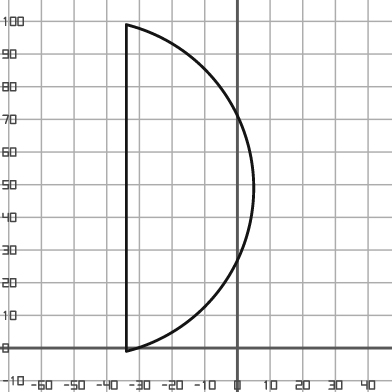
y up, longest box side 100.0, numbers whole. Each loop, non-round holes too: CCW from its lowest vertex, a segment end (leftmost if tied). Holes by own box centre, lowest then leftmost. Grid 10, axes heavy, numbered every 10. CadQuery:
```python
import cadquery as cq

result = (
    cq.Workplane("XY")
    .moveTo(-34.0, -1.0)
    .threePointArc((5.0, 49.0), (-34.0, 99.0))
    .close()
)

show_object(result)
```